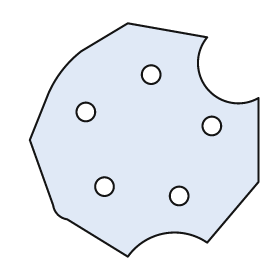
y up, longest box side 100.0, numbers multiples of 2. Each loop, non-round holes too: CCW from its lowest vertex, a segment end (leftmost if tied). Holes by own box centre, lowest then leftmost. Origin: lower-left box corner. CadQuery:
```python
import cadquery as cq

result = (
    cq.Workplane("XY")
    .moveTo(42.0, 0.0)
    .threePointArc((58.0, 10.0), (76.0, 6.0))
    .lineTo(98.0, 32.0)
    .lineTo(98.0, 68.0)
    .threePointArc((76.0, 72.0), (76.0, 94.0))
    .lineTo(42.0, 100.0)
    .lineTo(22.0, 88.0)
    .threePointArc((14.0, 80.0), (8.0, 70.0))
    .lineTo(0.0, 50.0)
    .lineTo(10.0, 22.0)
    .threePointArc((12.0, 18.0), (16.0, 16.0))
    .close()
    .moveTo(64.0, 26.0)
    .circle(4.0)
    .moveTo(32.0, 30.0)
    .circle(4.0)
    .moveTo(78.0, 56.0)
    .circle(4.0)
    .moveTo(24.0, 62.0)
    .circle(4.0)
    .moveTo(52.0, 78.0)
    .circle(4.0)
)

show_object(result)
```